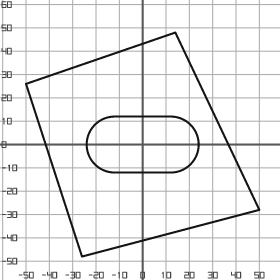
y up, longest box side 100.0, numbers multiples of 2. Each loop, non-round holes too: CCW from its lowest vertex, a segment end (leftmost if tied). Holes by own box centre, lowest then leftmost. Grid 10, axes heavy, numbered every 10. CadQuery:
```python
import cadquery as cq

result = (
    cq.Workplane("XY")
    .moveTo(-26.0, -48.0)
    .lineTo(50.0, -28.0)
    .lineTo(14.0, 48.0)
    .lineTo(-50.0, 26.0)
    .close()
    .moveTo(-12.0, -12.0)
    .lineTo(12.0, -12.0)
    .threePointArc((24.0, 0.0), (12.0, 12.0))
    .lineTo(-12.0, 12.0)
    .threePointArc((-24.0, 0.0), (-12.0, -12.0))
    .close()
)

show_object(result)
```